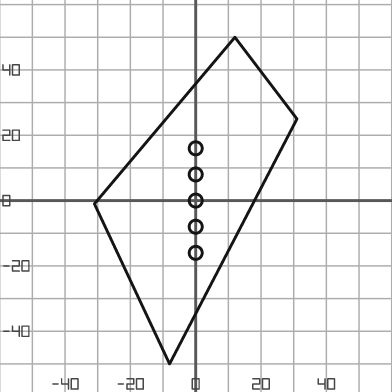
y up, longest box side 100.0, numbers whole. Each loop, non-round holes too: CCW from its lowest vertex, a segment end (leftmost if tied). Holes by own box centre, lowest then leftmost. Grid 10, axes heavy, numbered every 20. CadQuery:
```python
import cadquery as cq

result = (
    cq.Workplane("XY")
    .moveTo(-8.0, -50.0)
    .lineTo(31.0, 25.0)
    .lineTo(12.0, 50.0)
    .lineTo(-31.0, -1.0)
    .close()
    .moveTo(0.0, -16.0)
    .circle(2.0)
    .moveTo(0.0, -8.0)
    .circle(2.0)
    .moveTo(0.0, 0.0)
    .circle(2.0)
    .moveTo(0.0, 8.0)
    .circle(2.0)
    .moveTo(0.0, 16.0)
    .circle(2.0)
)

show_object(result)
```